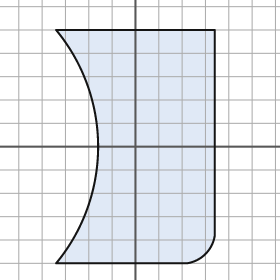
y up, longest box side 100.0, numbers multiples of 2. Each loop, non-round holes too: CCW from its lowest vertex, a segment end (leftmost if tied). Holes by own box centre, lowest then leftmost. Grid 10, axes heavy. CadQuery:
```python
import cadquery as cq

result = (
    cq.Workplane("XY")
    .moveTo(-34.0, -50.0)
    .lineTo(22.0, -50.0)
    .threePointArc((30.0, -46.0), (34.0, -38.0))
    .lineTo(34.0, 50.0)
    .lineTo(-34.0, 50.0)
    .threePointArc((-16.0, 0.0), (-34.0, -50.0))
    .close()
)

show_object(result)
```